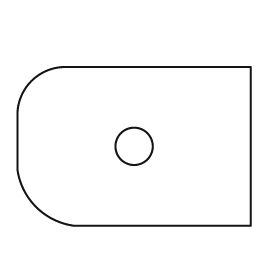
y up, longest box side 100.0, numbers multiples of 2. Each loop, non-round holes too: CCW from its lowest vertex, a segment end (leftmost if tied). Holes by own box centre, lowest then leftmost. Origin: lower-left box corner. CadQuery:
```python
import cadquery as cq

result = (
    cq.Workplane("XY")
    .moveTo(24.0, 0.0)
    .lineTo(100.0, 0.0)
    .lineTo(100.0, 68.0)
    .lineTo(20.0, 68.0)
    .threePointArc((6.0, 62.0), (0.0, 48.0))
    .lineTo(0.0, 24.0)
    .threePointArc((8.0, 8.0), (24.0, 0.0))
    .close()
    .moveTo(50.0, 34.0)
    .circle(8.0)
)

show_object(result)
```